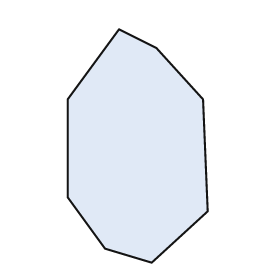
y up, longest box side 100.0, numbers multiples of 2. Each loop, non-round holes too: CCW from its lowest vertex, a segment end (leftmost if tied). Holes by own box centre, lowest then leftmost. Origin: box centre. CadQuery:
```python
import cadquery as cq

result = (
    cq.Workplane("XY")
    .moveTo(6.0, -50.0)
    .lineTo(30.0, -28.0)
    .lineTo(28.0, 20.0)
    .lineTo(8.0, 42.0)
    .lineTo(-8.0, 50.0)
    .lineTo(-30.0, 20.0)
    .lineTo(-30.0, -22.0)
    .lineTo(-14.0, -44.0)
    .close()
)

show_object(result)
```